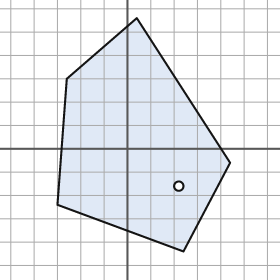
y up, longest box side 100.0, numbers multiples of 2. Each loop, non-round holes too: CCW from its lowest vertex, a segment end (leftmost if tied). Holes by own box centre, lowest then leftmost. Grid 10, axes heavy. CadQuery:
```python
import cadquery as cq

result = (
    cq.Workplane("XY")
    .moveTo(24.0, -44.0)
    .lineTo(44.0, -6.0)
    .lineTo(4.0, 56.0)
    .lineTo(-26.0, 30.0)
    .lineTo(-30.0, -24.0)
    .close()
    .moveTo(22.0, -16.0)
    .circle(2.0)
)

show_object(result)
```